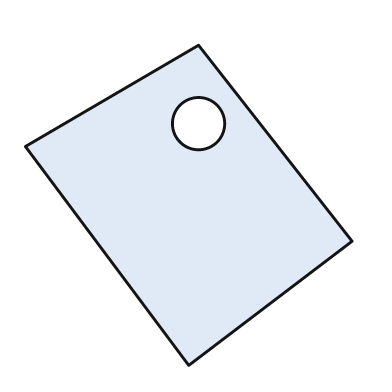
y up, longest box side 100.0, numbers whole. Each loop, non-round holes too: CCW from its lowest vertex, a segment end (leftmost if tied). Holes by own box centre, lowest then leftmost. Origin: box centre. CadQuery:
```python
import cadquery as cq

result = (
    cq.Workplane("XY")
    .moveTo(0.0, -49.0)
    .lineTo(50.0, -11.0)
    .lineTo(3.0, 49.0)
    .lineTo(-50.0, 18.0)
    .close()
    .moveTo(3.0, 25.0)
    .circle(8.0)
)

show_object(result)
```